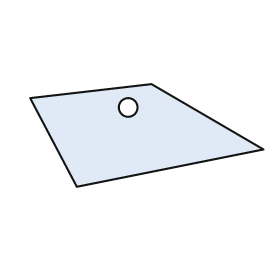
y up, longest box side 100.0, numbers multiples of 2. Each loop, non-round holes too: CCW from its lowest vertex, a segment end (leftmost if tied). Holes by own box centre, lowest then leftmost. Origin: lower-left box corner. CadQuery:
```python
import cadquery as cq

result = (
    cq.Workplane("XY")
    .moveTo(20.0, 0.0)
    .lineTo(100.0, 16.0)
    .lineTo(52.0, 44.0)
    .lineTo(0.0, 38.0)
    .close()
    .moveTo(42.0, 34.0)
    .circle(4.0)
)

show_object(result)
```